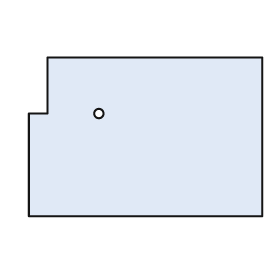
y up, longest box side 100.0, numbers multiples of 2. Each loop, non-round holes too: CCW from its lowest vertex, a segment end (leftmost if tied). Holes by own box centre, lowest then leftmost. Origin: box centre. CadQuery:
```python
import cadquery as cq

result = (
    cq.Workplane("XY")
    .moveTo(-50.0, -34.0)
    .lineTo(50.0, -34.0)
    .lineTo(50.0, 34.0)
    .lineTo(-42.0, 34.0)
    .lineTo(-42.0, 10.0)
    .lineTo(-50.0, 10.0)
    .close()
    .moveTo(-20.0, 10.0)
    .circle(2.0)
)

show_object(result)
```